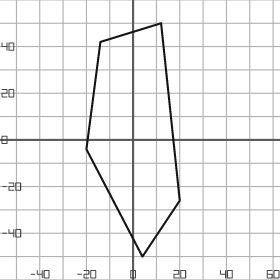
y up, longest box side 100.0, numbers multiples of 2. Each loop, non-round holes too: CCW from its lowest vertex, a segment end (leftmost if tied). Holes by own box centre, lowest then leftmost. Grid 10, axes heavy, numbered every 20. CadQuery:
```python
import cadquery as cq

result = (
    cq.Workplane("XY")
    .moveTo(4.0, -50.0)
    .lineTo(20.0, -26.0)
    .lineTo(12.0, 50.0)
    .lineTo(-14.0, 42.0)
    .lineTo(-20.0, -4.0)
    .close()
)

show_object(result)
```